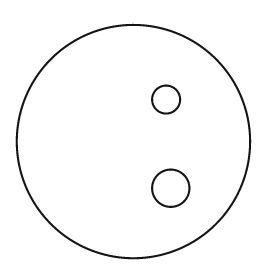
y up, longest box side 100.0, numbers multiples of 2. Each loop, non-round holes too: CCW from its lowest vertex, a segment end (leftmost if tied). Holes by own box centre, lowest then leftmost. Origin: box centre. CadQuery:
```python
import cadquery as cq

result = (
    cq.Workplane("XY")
    .moveTo(0.0, 0.0)
    .circle(50.0)
    .moveTo(16.0, -20.0)
    .circle(8.0)
    .moveTo(14.0, 18.0)
    .circle(6.0)
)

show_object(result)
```